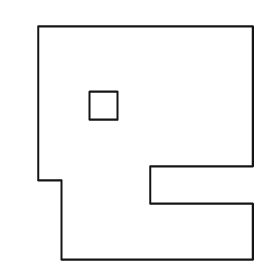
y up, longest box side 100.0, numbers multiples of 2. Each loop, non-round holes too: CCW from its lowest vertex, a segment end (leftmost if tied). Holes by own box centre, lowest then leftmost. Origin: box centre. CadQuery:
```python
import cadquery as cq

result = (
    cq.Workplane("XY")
    .moveTo(-36.0, -50.0)
    .lineTo(46.0, -50.0)
    .lineTo(46.0, -26.0)
    .lineTo(2.0, -26.0)
    .lineTo(2.0, -10.0)
    .lineTo(46.0, -10.0)
    .lineTo(46.0, 50.0)
    .lineTo(-46.0, 50.0)
    .lineTo(-46.0, -16.0)
    .lineTo(-36.0, -16.0)
    .close()
    .moveTo(-24.0, 10.0)
    .lineTo(-12.0, 10.0)
    .lineTo(-12.0, 22.0)
    .lineTo(-24.0, 22.0)
    .close()
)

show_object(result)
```